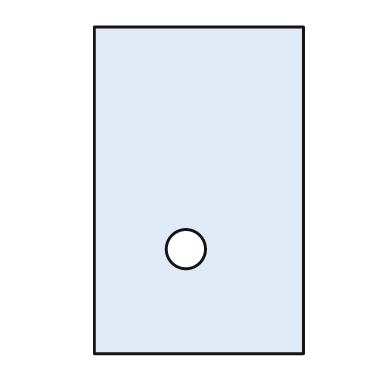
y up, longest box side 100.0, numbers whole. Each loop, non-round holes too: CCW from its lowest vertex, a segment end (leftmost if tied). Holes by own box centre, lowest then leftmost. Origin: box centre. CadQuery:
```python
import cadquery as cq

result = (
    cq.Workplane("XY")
    .moveTo(-32.0, -50.0)
    .lineTo(32.0, -50.0)
    .lineTo(32.0, 50.0)
    .lineTo(-32.0, 50.0)
    .close()
    .moveTo(-4.0, -18.0)
    .circle(6.0)
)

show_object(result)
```